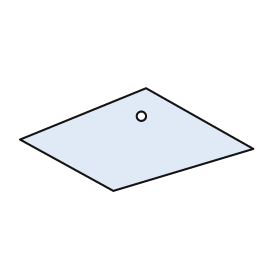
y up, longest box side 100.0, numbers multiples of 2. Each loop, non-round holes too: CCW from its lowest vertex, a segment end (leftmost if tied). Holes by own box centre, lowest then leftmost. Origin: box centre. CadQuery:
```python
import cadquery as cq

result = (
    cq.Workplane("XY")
    .moveTo(-10.0, -22.0)
    .lineTo(50.0, -4.0)
    .lineTo(4.0, 22.0)
    .lineTo(-50.0, 0.0)
    .close()
    .moveTo(2.0, 10.0)
    .circle(2.0)
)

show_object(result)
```